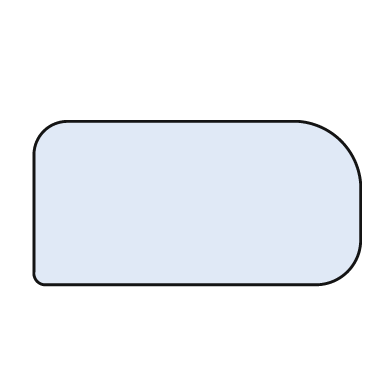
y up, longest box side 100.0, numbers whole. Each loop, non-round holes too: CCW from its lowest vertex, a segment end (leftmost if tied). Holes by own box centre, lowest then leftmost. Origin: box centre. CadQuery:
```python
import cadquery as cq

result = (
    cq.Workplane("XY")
    .moveTo(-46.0, -25.0)
    .lineTo(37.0, -25.0)
    .threePointArc((46.0, -21.0), (50.0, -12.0))
    .lineTo(50.0, 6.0)
    .threePointArc((44.0, 19.0), (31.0, 25.0))
    .lineTo(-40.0, 25.0)
    .threePointArc((-47.0, 22.0), (-50.0, 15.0))
    .lineTo(-50.0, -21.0)
    .threePointArc((-49.0, -24.0), (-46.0, -25.0))
    .close()
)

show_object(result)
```